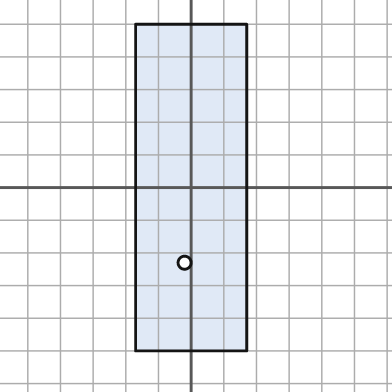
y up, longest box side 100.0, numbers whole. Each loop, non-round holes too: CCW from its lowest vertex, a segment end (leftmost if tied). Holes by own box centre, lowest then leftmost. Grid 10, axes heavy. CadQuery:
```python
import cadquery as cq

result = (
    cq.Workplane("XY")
    .moveTo(-17.0, -50.0)
    .lineTo(17.0, -50.0)
    .lineTo(17.0, 50.0)
    .lineTo(-17.0, 50.0)
    .close()
    .moveTo(-2.0, -23.0)
    .circle(2.0)
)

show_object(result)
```